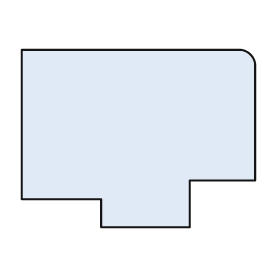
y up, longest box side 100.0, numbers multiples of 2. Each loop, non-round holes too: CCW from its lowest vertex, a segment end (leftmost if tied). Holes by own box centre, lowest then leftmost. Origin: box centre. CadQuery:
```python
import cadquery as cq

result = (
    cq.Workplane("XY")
    .moveTo(-16.0, -38.0)
    .lineTo(22.0, -38.0)
    .lineTo(22.0, -18.0)
    .lineTo(50.0, -18.0)
    .lineTo(50.0, 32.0)
    .threePointArc((48.0, 36.0), (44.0, 38.0))
    .lineTo(-50.0, 38.0)
    .lineTo(-50.0, -26.0)
    .lineTo(-16.0, -26.0)
    .close()
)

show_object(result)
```